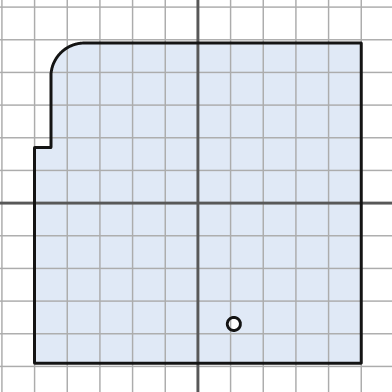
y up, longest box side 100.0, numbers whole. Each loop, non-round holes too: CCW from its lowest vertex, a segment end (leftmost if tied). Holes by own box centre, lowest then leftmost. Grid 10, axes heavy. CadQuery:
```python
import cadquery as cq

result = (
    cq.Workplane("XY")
    .moveTo(-50.0, -49.0)
    .lineTo(50.0, -49.0)
    .lineTo(50.0, 49.0)
    .lineTo(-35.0, 49.0)
    .threePointArc((-42.0, 46.0), (-45.0, 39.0))
    .lineTo(-45.0, 17.0)
    .lineTo(-50.0, 17.0)
    .close()
    .moveTo(11.0, -37.0)
    .circle(2.0)
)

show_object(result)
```